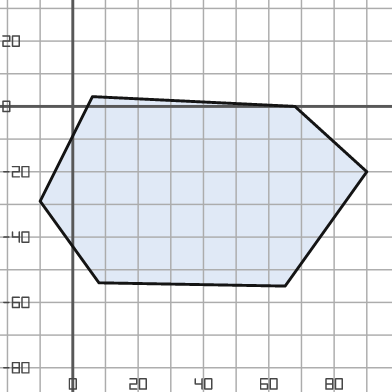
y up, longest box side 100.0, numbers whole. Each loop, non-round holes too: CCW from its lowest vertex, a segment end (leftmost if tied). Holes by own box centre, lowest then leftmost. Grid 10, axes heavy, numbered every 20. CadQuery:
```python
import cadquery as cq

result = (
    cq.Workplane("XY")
    .moveTo(65.0, -55.0)
    .lineTo(90.0, -20.0)
    .lineTo(68.0, 0.0)
    .lineTo(6.0, 3.0)
    .lineTo(-10.0, -29.0)
    .lineTo(8.0, -54.0)
    .close()
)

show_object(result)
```